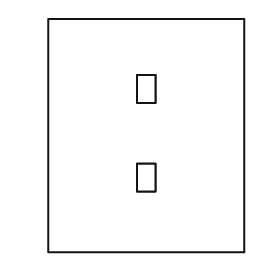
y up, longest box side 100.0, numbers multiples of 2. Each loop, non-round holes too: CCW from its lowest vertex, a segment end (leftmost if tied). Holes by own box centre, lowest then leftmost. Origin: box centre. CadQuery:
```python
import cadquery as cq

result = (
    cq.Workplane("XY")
    .moveTo(-42.0, -50.0)
    .lineTo(42.0, -50.0)
    .lineTo(42.0, 50.0)
    .lineTo(-42.0, 50.0)
    .close()
    .moveTo(-4.0, -24.0)
    .lineTo(4.0, -24.0)
    .lineTo(4.0, -12.0)
    .lineTo(-4.0, -12.0)
    .close()
    .moveTo(-4.0, 14.0)
    .lineTo(4.0, 14.0)
    .lineTo(4.0, 26.0)
    .lineTo(-4.0, 26.0)
    .close()
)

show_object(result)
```